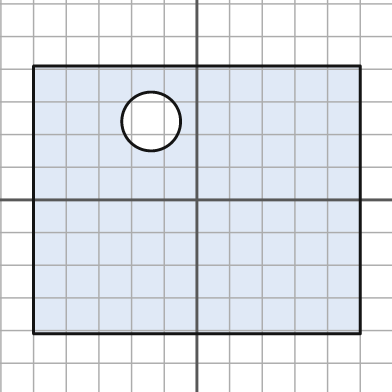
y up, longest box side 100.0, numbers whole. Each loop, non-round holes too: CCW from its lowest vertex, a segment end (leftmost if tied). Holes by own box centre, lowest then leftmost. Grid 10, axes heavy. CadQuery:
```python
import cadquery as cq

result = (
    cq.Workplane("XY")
    .moveTo(-50.0, -41.0)
    .lineTo(50.0, -41.0)
    .lineTo(50.0, 41.0)
    .lineTo(-50.0, 41.0)
    .close()
    .moveTo(-14.0, 24.0)
    .circle(9.0)
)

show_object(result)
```